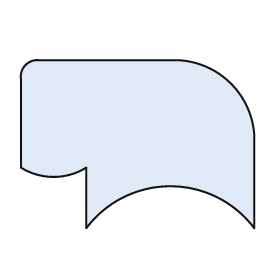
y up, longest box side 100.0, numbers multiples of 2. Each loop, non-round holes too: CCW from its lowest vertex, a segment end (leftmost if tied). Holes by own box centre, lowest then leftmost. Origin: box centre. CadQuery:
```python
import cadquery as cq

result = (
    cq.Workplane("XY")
    .moveTo(-22.0, -36.0)
    .threePointArc((14.0, -18.0), (50.0, -36.0))
    .lineTo(50.0, 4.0)
    .threePointArc((40.0, 26.0), (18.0, 36.0))
    .lineTo(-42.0, 36.0)
    .threePointArc((-48.0, 34.0), (-50.0, 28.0))
    .lineTo(-50.0, -10.0)
    .threePointArc((-36.0, -14.0), (-22.0, -10.0))
    .close()
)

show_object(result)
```